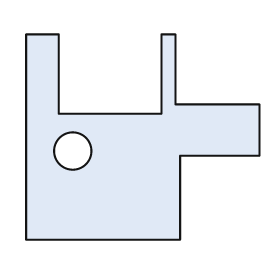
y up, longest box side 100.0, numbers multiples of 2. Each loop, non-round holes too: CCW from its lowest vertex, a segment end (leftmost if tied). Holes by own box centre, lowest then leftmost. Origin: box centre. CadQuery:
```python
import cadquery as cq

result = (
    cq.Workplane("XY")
    .moveTo(-50.0, -44.0)
    .lineTo(16.0, -44.0)
    .lineTo(16.0, -8.0)
    .lineTo(50.0, -8.0)
    .lineTo(50.0, 14.0)
    .lineTo(14.0, 14.0)
    .lineTo(14.0, 44.0)
    .lineTo(8.0, 44.0)
    .lineTo(8.0, 10.0)
    .lineTo(-36.0, 10.0)
    .lineTo(-36.0, 44.0)
    .lineTo(-50.0, 44.0)
    .close()
    .moveTo(-30.0, -6.0)
    .circle(8.0)
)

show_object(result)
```